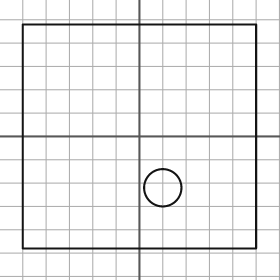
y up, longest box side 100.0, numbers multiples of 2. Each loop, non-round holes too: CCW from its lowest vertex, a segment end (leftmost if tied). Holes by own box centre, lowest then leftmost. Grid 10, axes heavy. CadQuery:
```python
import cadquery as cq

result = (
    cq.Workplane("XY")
    .moveTo(-50.0, -48.0)
    .lineTo(50.0, -48.0)
    .lineTo(50.0, 48.0)
    .lineTo(-50.0, 48.0)
    .close()
    .moveTo(10.0, -22.0)
    .circle(8.0)
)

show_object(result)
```